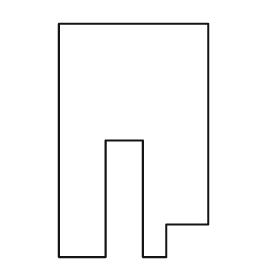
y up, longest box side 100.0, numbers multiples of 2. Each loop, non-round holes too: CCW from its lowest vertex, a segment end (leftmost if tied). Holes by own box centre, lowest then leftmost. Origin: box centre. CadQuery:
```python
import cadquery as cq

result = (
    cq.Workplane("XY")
    .moveTo(-32.0, -50.0)
    .lineTo(-12.0, -50.0)
    .lineTo(-12.0, 0.0)
    .lineTo(4.0, 0.0)
    .lineTo(4.0, -50.0)
    .lineTo(14.0, -50.0)
    .lineTo(14.0, -36.0)
    .lineTo(32.0, -36.0)
    .lineTo(32.0, 50.0)
    .lineTo(-32.0, 50.0)
    .close()
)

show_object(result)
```